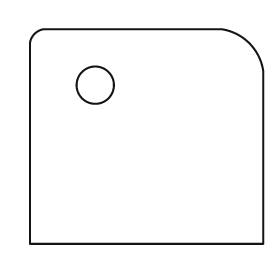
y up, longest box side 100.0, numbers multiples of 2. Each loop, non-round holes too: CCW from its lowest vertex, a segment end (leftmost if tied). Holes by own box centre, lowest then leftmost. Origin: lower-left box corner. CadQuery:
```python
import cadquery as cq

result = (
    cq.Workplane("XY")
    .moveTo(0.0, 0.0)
    .lineTo(100.0, 0.0)
    .lineTo(100.0, 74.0)
    .threePointArc((94.0, 86.0), (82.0, 92.0))
    .lineTo(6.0, 92.0)
    .threePointArc((2.0, 90.0), (0.0, 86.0))
    .close()
    .moveTo(28.0, 68.0)
    .circle(8.0)
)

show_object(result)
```